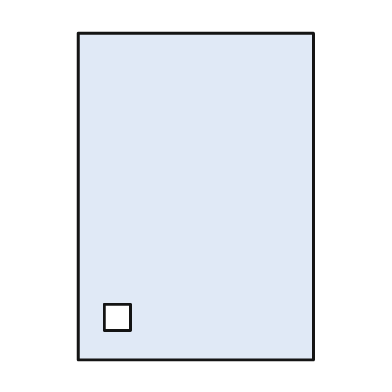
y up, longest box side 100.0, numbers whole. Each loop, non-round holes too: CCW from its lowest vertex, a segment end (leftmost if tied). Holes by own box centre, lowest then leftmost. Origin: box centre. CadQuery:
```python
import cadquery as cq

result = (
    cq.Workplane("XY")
    .moveTo(-36.0, -50.0)
    .lineTo(36.0, -50.0)
    .lineTo(36.0, 50.0)
    .lineTo(-36.0, 50.0)
    .close()
    .moveTo(-28.0, -41.0)
    .lineTo(-20.0, -41.0)
    .lineTo(-20.0, -33.0)
    .lineTo(-28.0, -33.0)
    .close()
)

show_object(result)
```